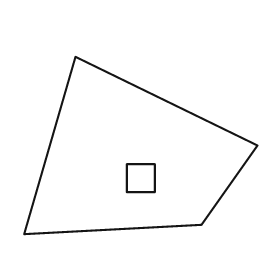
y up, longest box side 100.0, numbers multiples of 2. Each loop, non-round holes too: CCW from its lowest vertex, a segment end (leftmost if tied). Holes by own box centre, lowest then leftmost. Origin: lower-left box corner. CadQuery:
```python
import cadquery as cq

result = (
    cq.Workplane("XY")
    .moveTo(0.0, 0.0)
    .lineTo(76.0, 4.0)
    .lineTo(100.0, 38.0)
    .lineTo(22.0, 76.0)
    .close()
    .moveTo(44.0, 18.0)
    .lineTo(56.0, 18.0)
    .lineTo(56.0, 30.0)
    .lineTo(44.0, 30.0)
    .close()
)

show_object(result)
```